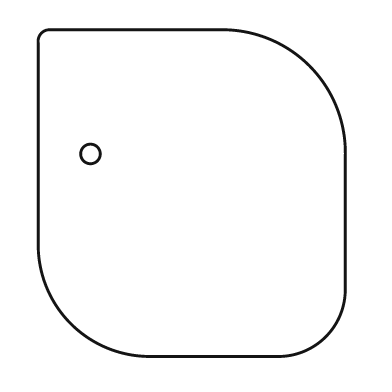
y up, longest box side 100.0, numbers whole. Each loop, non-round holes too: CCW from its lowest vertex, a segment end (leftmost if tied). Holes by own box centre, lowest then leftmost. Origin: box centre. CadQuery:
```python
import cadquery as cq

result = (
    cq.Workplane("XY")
    .moveTo(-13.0, -50.0)
    .lineTo(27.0, -50.0)
    .threePointArc((41.0, -44.0), (47.0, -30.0))
    .lineTo(47.0, 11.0)
    .threePointArc((36.0, 39.0), (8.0, 50.0))
    .lineTo(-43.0, 50.0)
    .threePointArc((-46.0, 49.0), (-47.0, 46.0))
    .lineTo(-47.0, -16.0)
    .threePointArc((-37.0, -40.0), (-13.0, -50.0))
    .close()
    .moveTo(-31.0, 12.0)
    .circle(3.0)
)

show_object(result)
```